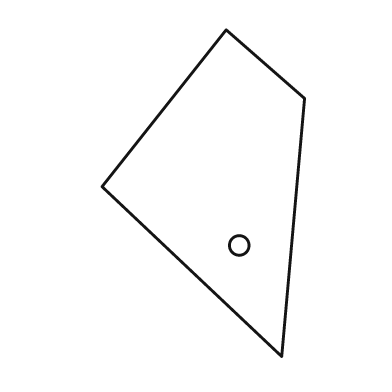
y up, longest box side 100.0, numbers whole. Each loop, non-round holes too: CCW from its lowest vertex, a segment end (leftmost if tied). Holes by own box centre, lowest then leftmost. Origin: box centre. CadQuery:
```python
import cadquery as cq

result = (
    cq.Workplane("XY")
    .moveTo(24.0, -50.0)
    .lineTo(31.0, 29.0)
    .lineTo(7.0, 50.0)
    .lineTo(-31.0, 2.0)
    .close()
    .moveTo(11.0, -16.0)
    .circle(3.0)
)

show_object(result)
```